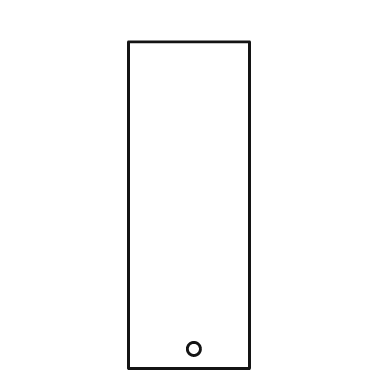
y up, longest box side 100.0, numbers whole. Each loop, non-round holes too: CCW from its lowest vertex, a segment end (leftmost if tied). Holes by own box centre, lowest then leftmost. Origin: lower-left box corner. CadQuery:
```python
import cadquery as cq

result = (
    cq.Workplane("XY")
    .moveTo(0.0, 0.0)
    .lineTo(37.0, 0.0)
    .lineTo(37.0, 100.0)
    .lineTo(0.0, 100.0)
    .close()
    .moveTo(20.0, 6.0)
    .circle(2.0)
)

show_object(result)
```